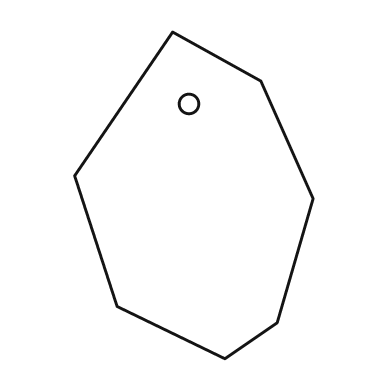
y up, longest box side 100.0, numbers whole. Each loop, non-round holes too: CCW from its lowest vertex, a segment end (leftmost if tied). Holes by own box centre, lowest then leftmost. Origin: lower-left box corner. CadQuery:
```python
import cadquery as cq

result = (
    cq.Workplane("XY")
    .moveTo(46.0, 0.0)
    .lineTo(62.0, 11.0)
    .lineTo(73.0, 49.0)
    .lineTo(57.0, 85.0)
    .lineTo(30.0, 100.0)
    .lineTo(0.0, 56.0)
    .lineTo(13.0, 16.0)
    .close()
    .moveTo(35.0, 78.0)
    .circle(3.0)
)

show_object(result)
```